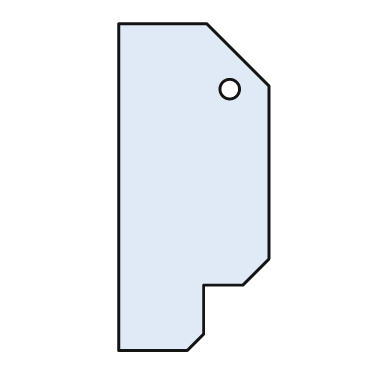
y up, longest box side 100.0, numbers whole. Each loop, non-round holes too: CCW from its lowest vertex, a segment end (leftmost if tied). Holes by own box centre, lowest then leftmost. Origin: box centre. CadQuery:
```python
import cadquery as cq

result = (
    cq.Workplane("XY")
    .moveTo(-23.0, -50.0)
    .lineTo(-2.0, -50.0)
    .lineTo(3.0, -45.0)
    .lineTo(3.0, -30.0)
    .lineTo(15.0, -30.0)
    .lineTo(23.0, -22.0)
    .lineTo(23.0, 31.0)
    .lineTo(4.0, 50.0)
    .lineTo(-23.0, 50.0)
    .close()
    .moveTo(11.0, 30.0)
    .circle(3.0)
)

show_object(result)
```